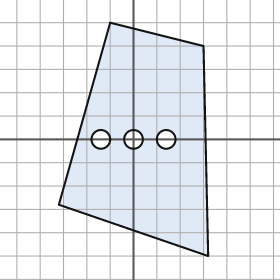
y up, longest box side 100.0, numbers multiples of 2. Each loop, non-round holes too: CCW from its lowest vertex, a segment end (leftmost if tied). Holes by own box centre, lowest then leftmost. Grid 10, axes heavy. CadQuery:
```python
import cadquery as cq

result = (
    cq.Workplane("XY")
    .moveTo(32.0, -50.0)
    .lineTo(30.0, 40.0)
    .lineTo(-10.0, 50.0)
    .lineTo(-32.0, -28.0)
    .close()
    .moveTo(-14.0, 0.0)
    .circle(4.0)
    .moveTo(0.0, 0.0)
    .circle(4.0)
    .moveTo(14.0, 0.0)
    .circle(4.0)
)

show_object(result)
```